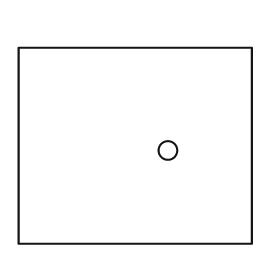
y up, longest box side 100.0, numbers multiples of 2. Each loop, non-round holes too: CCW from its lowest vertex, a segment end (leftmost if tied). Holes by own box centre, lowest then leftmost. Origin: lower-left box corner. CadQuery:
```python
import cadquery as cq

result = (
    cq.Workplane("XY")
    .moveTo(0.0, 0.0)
    .lineTo(100.0, 0.0)
    .lineTo(100.0, 84.0)
    .lineTo(0.0, 84.0)
    .close()
    .moveTo(64.0, 40.0)
    .circle(4.0)
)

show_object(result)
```